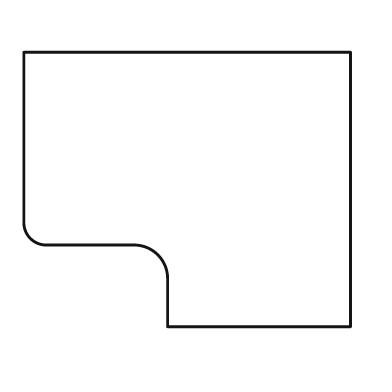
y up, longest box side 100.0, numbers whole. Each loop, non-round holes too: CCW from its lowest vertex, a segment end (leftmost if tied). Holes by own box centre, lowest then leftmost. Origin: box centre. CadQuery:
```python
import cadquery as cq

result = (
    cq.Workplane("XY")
    .moveTo(-6.0, -42.0)
    .lineTo(50.0, -42.0)
    .lineTo(50.0, 42.0)
    .lineTo(-50.0, 42.0)
    .lineTo(-50.0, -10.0)
    .threePointArc((-48.0, -15.0), (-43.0, -17.0))
    .lineTo(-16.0, -17.0)
    .threePointArc((-9.0, -20.0), (-6.0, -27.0))
    .close()
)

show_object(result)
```